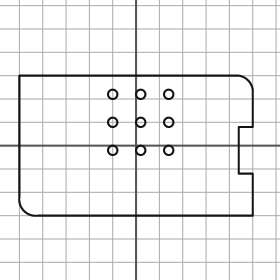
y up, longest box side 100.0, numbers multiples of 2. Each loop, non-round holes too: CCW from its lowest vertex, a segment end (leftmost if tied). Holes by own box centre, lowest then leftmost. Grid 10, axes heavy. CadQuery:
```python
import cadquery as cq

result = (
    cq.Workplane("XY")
    .moveTo(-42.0, -30.0)
    .lineTo(50.0, -30.0)
    .lineTo(50.0, -12.0)
    .lineTo(44.0, -12.0)
    .lineTo(44.0, 8.0)
    .lineTo(50.0, 8.0)
    .lineTo(50.0, 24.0)
    .threePointArc((48.0, 28.0), (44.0, 30.0))
    .lineTo(-50.0, 30.0)
    .lineTo(-50.0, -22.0)
    .threePointArc((-48.0, -28.0), (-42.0, -30.0))
    .close()
    .moveTo(-10.0, -2.0)
    .circle(2.0)
    .moveTo(2.0, -2.0)
    .circle(2.0)
    .moveTo(14.0, -2.0)
    .circle(2.0)
    .moveTo(-10.0, 10.0)
    .circle(2.0)
    .moveTo(2.0, 10.0)
    .circle(2.0)
    .moveTo(14.0, 10.0)
    .circle(2.0)
    .moveTo(-10.0, 22.0)
    .circle(2.0)
    .moveTo(2.0, 22.0)
    .circle(2.0)
    .moveTo(14.0, 22.0)
    .circle(2.0)
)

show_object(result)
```